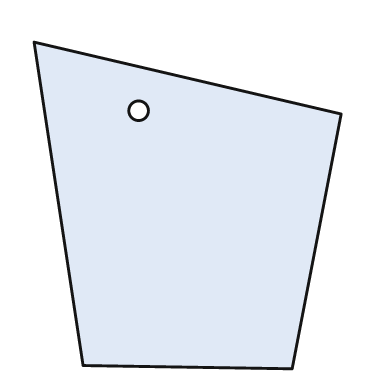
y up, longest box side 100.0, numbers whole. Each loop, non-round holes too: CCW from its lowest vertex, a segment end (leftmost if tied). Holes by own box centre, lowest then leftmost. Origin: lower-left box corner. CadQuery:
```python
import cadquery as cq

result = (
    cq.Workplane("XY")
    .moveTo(79.0, 0.0)
    .lineTo(94.0, 78.0)
    .lineTo(0.0, 100.0)
    .lineTo(15.0, 1.0)
    .close()
    .moveTo(32.0, 79.0)
    .circle(3.0)
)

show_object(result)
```